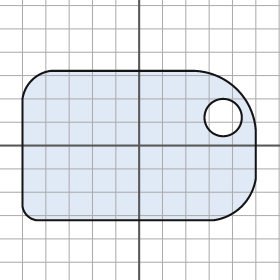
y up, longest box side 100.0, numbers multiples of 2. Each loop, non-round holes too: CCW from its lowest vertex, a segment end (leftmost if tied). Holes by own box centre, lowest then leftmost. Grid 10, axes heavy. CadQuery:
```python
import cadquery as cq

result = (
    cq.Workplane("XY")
    .moveTo(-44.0, -32.0)
    .lineTo(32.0, -32.0)
    .threePointArc((44.0, -26.0), (50.0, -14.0))
    .lineTo(50.0, 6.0)
    .threePointArc((42.0, 24.0), (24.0, 32.0))
    .lineTo(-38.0, 32.0)
    .threePointArc((-46.0, 28.0), (-50.0, 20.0))
    .lineTo(-50.0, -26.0)
    .threePointArc((-48.0, -30.0), (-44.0, -32.0))
    .close()
    .moveTo(36.0, 12.0)
    .circle(8.0)
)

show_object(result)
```